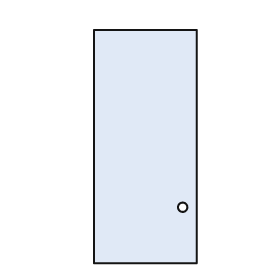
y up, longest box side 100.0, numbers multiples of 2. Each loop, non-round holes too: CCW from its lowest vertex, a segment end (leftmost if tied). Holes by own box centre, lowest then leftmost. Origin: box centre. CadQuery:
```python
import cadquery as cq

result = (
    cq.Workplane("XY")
    .moveTo(-22.0, -50.0)
    .lineTo(22.0, -50.0)
    .lineTo(22.0, 50.0)
    .lineTo(-22.0, 50.0)
    .close()
    .moveTo(16.0, -26.0)
    .circle(2.0)
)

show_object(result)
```